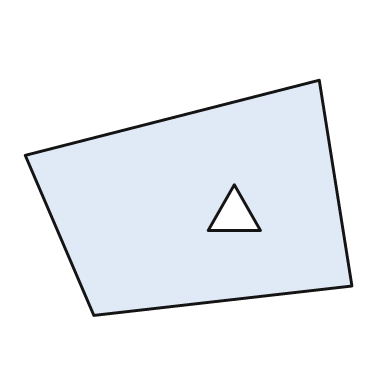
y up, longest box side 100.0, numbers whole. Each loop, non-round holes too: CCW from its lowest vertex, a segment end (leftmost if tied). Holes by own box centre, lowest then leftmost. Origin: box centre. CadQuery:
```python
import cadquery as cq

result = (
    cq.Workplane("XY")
    .moveTo(-29.0, -36.0)
    .lineTo(50.0, -27.0)
    .lineTo(40.0, 36.0)
    .lineTo(-50.0, 13.0)
    .close()
    .moveTo(6.0, -10.0)
    .lineTo(22.0, -10.0)
    .lineTo(14.0, 4.0)
    .close()
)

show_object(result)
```